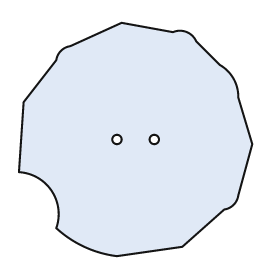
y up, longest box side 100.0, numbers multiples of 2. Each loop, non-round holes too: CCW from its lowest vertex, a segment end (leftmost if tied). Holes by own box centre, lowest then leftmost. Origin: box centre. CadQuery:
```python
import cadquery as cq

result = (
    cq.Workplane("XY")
    .moveTo(-8.0, -50.0)
    .lineTo(20.0, -46.0)
    .lineTo(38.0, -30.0)
    .threePointArc((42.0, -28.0), (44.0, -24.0))
    .lineTo(50.0, -2.0)
    .lineTo(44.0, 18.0)
    .threePointArc((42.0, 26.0), (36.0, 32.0))
    .lineTo(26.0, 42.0)
    .threePointArc((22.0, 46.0), (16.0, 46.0))
    .lineTo(-6.0, 50.0)
    .lineTo(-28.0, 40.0)
    .threePointArc((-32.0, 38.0), (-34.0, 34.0))
    .lineTo(-48.0, 16.0)
    .lineTo(-50.0, -14.0)
    .threePointArc((-36.0, -22.0), (-34.0, -38.0))
    .threePointArc((-22.0, -46.0), (-8.0, -50.0))
    .close()
    .moveTo(-8.0, 0.0)
    .circle(2.0)
    .moveTo(8.0, 0.0)
    .circle(2.0)
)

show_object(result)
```